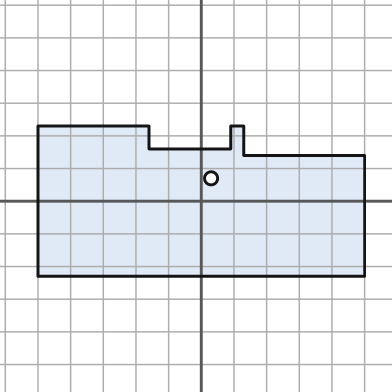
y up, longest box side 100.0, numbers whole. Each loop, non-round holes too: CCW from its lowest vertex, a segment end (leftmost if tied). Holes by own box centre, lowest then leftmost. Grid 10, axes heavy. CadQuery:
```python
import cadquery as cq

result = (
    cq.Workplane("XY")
    .moveTo(-50.0, -23.0)
    .lineTo(50.0, -23.0)
    .lineTo(50.0, 14.0)
    .lineTo(13.0, 14.0)
    .lineTo(13.0, 23.0)
    .lineTo(9.0, 23.0)
    .lineTo(9.0, 16.0)
    .lineTo(-16.0, 16.0)
    .lineTo(-16.0, 23.0)
    .lineTo(-50.0, 23.0)
    .close()
    .moveTo(3.0, 7.0)
    .circle(2.0)
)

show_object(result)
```